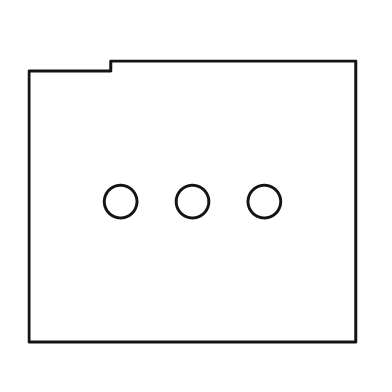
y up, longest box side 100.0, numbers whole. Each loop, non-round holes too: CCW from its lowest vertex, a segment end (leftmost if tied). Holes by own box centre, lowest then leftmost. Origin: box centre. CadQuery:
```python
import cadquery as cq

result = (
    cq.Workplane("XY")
    .moveTo(-50.0, -43.0)
    .lineTo(50.0, -43.0)
    .lineTo(50.0, 43.0)
    .lineTo(-25.0, 43.0)
    .lineTo(-25.0, 40.0)
    .lineTo(-50.0, 40.0)
    .close()
    .moveTo(-22.0, 0.0)
    .circle(5.0)
    .moveTo(0.0, 0.0)
    .circle(5.0)
    .moveTo(22.0, 0.0)
    .circle(5.0)
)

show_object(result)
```